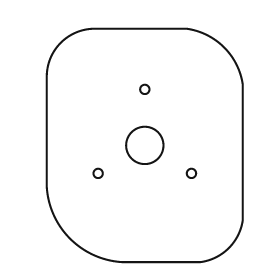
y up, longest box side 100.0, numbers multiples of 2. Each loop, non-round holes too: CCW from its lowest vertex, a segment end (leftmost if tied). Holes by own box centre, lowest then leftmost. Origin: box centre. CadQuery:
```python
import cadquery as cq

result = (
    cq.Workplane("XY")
    .moveTo(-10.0, -50.0)
    .lineTo(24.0, -50.0)
    .threePointArc((36.0, -44.0), (42.0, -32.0))
    .lineTo(42.0, 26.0)
    .threePointArc((34.0, 42.0), (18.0, 50.0))
    .lineTo(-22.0, 50.0)
    .threePointArc((-36.0, 44.0), (-42.0, 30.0))
    .lineTo(-42.0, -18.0)
    .threePointArc((-32.0, -40.0), (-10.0, -50.0))
    .close()
    .moveTo(-20.0, -12.0)
    .circle(2.0)
    .moveTo(20.0, -12.0)
    .circle(2.0)
    .moveTo(0.0, 0.0)
    .circle(8.0)
    .moveTo(0.0, 24.0)
    .circle(2.0)
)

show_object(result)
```